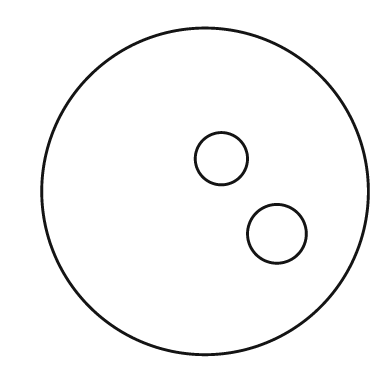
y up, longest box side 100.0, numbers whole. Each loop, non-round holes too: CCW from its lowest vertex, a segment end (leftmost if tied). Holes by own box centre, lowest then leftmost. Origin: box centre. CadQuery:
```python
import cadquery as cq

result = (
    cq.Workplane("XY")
    .moveTo(0.0, 0.0)
    .circle(50.0)
    .moveTo(22.0, -13.0)
    .circle(9.0)
    .moveTo(5.0, 10.0)
    .circle(8.0)
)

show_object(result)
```